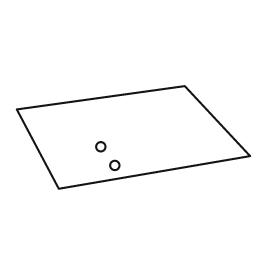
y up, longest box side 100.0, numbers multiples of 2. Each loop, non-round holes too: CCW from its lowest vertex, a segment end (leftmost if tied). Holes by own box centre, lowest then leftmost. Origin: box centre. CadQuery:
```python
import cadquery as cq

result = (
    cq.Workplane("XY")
    .moveTo(-32.0, -22.0)
    .lineTo(50.0, -8.0)
    .lineTo(22.0, 22.0)
    .lineTo(-50.0, 12.0)
    .close()
    .moveTo(-8.0, -12.0)
    .circle(2.0)
    .moveTo(-14.0, -4.0)
    .circle(2.0)
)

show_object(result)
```